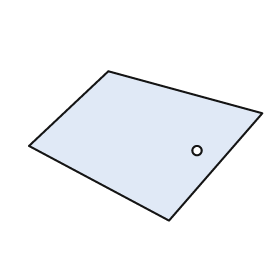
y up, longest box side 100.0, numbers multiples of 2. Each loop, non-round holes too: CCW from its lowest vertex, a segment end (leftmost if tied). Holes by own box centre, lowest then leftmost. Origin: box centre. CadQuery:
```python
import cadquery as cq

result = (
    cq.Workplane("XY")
    .moveTo(10.0, -32.0)
    .lineTo(50.0, 14.0)
    .lineTo(-16.0, 32.0)
    .lineTo(-50.0, 0.0)
    .close()
    .moveTo(22.0, -2.0)
    .circle(2.0)
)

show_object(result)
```